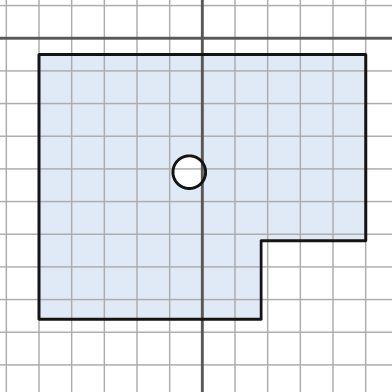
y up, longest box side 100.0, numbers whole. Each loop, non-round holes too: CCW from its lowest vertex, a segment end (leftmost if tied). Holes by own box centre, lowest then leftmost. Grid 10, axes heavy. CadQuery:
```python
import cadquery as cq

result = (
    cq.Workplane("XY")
    .moveTo(-50.0, -86.0)
    .lineTo(18.0, -86.0)
    .lineTo(18.0, -62.0)
    .lineTo(50.0, -62.0)
    .lineTo(50.0, -5.0)
    .lineTo(-50.0, -5.0)
    .close()
    .moveTo(-4.0, -41.0)
    .circle(5.0)
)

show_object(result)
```